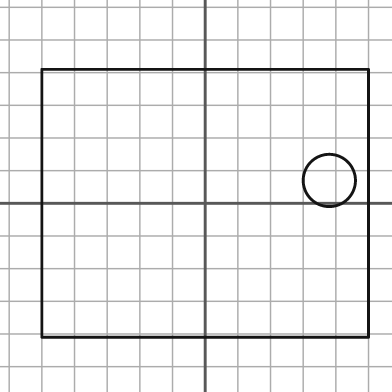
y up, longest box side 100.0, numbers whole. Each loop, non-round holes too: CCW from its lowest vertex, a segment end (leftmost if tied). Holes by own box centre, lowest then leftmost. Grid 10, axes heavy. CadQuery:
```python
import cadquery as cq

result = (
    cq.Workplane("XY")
    .moveTo(-50.0, -41.0)
    .lineTo(50.0, -41.0)
    .lineTo(50.0, 41.0)
    .lineTo(-50.0, 41.0)
    .close()
    .moveTo(38.0, 7.0)
    .circle(8.0)
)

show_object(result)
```